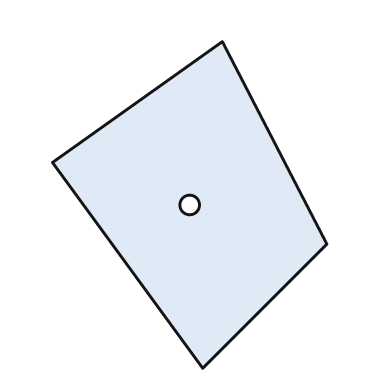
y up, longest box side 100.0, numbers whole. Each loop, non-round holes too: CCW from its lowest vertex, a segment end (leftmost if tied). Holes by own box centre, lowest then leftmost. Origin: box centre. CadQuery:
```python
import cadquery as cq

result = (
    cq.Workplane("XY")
    .moveTo(4.0, -50.0)
    .lineTo(42.0, -12.0)
    .lineTo(10.0, 50.0)
    .lineTo(-42.0, 13.0)
    .close()
    .moveTo(0.0, 0.0)
    .circle(3.0)
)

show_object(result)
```